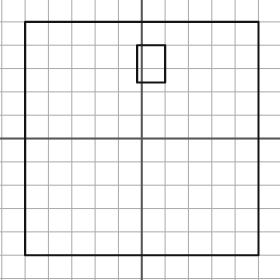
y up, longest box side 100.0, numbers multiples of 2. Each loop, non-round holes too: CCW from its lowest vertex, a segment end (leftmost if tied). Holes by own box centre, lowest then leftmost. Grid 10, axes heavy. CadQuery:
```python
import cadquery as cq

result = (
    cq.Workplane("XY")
    .moveTo(-50.0, -50.0)
    .lineTo(50.0, -50.0)
    .lineTo(50.0, 50.0)
    .lineTo(-50.0, 50.0)
    .close()
    .moveTo(-2.0, 24.0)
    .lineTo(10.0, 24.0)
    .lineTo(10.0, 40.0)
    .lineTo(-2.0, 40.0)
    .close()
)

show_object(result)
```